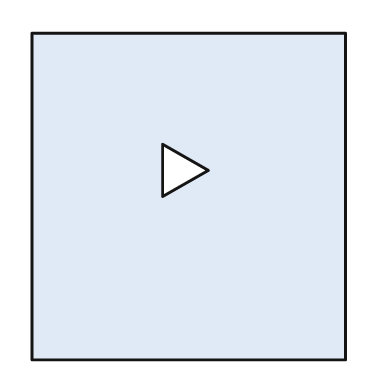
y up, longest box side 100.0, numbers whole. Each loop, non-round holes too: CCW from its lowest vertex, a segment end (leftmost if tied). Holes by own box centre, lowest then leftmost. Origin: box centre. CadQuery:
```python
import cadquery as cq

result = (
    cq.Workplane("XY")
    .moveTo(-48.0, -50.0)
    .lineTo(48.0, -50.0)
    .lineTo(48.0, 50.0)
    .lineTo(-48.0, 50.0)
    .close()
    .moveTo(-8.0, 0.0)
    .lineTo(6.0, 8.0)
    .lineTo(-8.0, 16.0)
    .close()
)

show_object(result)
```